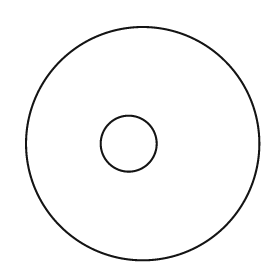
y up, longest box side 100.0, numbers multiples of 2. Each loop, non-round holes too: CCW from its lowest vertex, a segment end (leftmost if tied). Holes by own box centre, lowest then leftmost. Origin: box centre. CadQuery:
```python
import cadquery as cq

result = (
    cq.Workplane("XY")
    .moveTo(0.0, 0.0)
    .circle(50.0)
    .moveTo(-6.0, 0.0)
    .circle(12.0)
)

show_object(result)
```